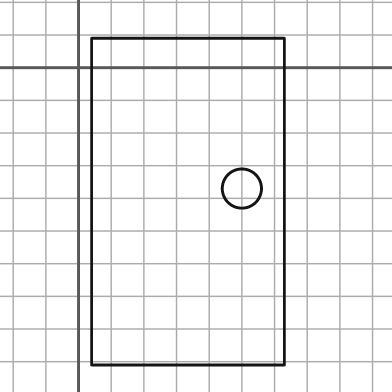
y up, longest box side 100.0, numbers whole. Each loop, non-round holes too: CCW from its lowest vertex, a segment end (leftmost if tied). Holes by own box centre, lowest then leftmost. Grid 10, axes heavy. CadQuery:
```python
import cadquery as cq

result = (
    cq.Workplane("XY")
    .moveTo(4.0, -91.0)
    .lineTo(63.0, -91.0)
    .lineTo(63.0, 9.0)
    .lineTo(4.0, 9.0)
    .close()
    .moveTo(50.0, -37.0)
    .circle(6.0)
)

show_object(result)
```